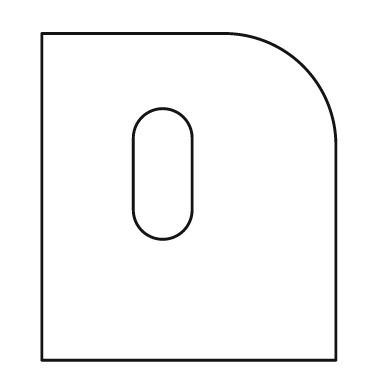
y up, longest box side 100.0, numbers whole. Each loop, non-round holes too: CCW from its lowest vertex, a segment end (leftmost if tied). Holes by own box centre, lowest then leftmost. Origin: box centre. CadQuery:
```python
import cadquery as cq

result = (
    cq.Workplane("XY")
    .moveTo(-45.0, -50.0)
    .lineTo(45.0, -50.0)
    .lineTo(45.0, 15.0)
    .threePointArc((35.0, 40.0), (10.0, 50.0))
    .lineTo(-45.0, 50.0)
    .close()
    .moveTo(-17.0, -4.0)
    .threePointArc((-8.0, -13.0), (1.0, -4.0))
    .lineTo(1.0, 18.0)
    .threePointArc((-8.0, 27.0), (-17.0, 18.0))
    .close()
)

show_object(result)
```